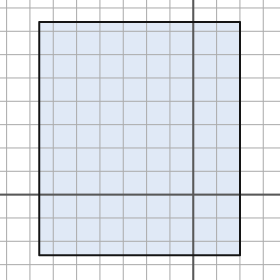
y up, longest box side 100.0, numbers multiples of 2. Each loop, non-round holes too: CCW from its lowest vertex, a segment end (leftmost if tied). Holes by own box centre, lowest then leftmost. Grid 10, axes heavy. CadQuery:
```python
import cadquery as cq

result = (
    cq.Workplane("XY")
    .moveTo(-66.0, -26.0)
    .lineTo(20.0, -26.0)
    .lineTo(20.0, 74.0)
    .lineTo(-66.0, 74.0)
    .close()
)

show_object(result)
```